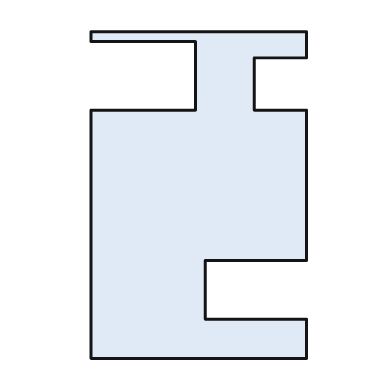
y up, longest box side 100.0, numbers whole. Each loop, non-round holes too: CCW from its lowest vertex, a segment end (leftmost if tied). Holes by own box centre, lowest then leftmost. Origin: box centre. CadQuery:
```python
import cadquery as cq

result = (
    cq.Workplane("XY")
    .moveTo(-33.0, -50.0)
    .lineTo(33.0, -50.0)
    .lineTo(33.0, -38.0)
    .lineTo(2.0, -38.0)
    .lineTo(2.0, -20.0)
    .lineTo(33.0, -20.0)
    .lineTo(33.0, 26.0)
    .lineTo(17.0, 26.0)
    .lineTo(17.0, 42.0)
    .lineTo(33.0, 42.0)
    .lineTo(33.0, 50.0)
    .lineTo(-33.0, 50.0)
    .lineTo(-33.0, 47.0)
    .lineTo(-1.0, 47.0)
    .lineTo(-1.0, 26.0)
    .lineTo(-33.0, 26.0)
    .close()
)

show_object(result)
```